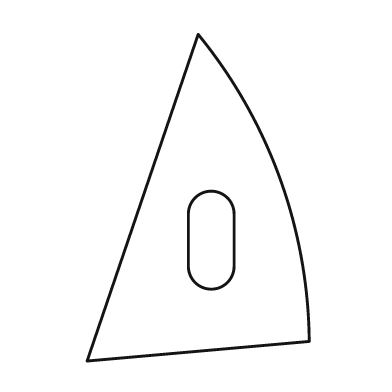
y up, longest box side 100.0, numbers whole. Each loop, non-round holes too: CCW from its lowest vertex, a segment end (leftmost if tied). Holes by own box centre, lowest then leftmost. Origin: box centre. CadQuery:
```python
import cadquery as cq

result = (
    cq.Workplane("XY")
    .moveTo(-34.0, -50.0)
    .lineTo(34.0, -44.0)
    .threePointArc((25.0, 6.0), (0.0, 50.0))
    .close()
    .moveTo(-3.0, -21.0)
    .threePointArc((4.0, -28.0), (11.0, -21.0))
    .lineTo(11.0, -5.0)
    .threePointArc((4.0, 2.0), (-3.0, -5.0))
    .close()
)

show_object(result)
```